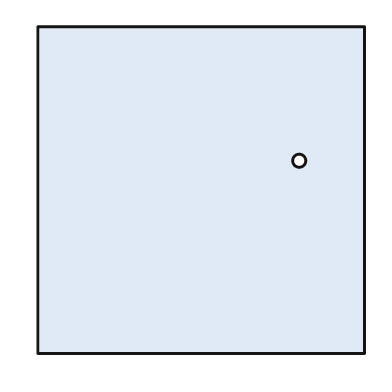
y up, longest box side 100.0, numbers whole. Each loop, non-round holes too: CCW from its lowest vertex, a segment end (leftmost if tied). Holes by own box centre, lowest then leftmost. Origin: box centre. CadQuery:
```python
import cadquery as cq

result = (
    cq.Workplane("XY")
    .moveTo(-50.0, -50.0)
    .lineTo(50.0, -50.0)
    .lineTo(50.0, 50.0)
    .lineTo(-50.0, 50.0)
    .close()
    .moveTo(30.0, 9.0)
    .circle(2.0)
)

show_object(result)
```